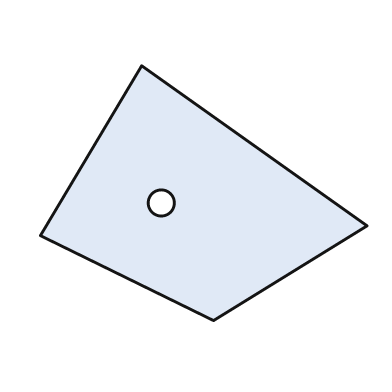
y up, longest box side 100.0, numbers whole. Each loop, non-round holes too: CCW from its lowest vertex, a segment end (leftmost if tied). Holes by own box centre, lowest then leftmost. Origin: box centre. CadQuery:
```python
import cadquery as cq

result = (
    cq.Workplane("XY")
    .moveTo(3.0, -39.0)
    .lineTo(50.0, -10.0)
    .lineTo(-19.0, 39.0)
    .lineTo(-50.0, -13.0)
    .close()
    .moveTo(-13.0, -3.0)
    .circle(4.0)
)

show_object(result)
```